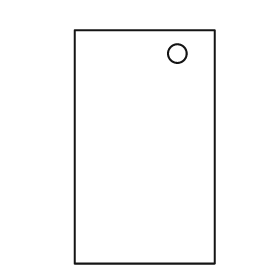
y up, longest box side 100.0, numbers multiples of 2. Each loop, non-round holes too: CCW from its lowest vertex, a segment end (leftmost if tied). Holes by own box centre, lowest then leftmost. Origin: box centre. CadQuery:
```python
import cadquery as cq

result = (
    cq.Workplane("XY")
    .moveTo(-30.0, -50.0)
    .lineTo(30.0, -50.0)
    .lineTo(30.0, 50.0)
    .lineTo(-30.0, 50.0)
    .close()
    .moveTo(14.0, 40.0)
    .circle(4.0)
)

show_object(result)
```